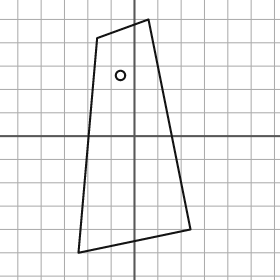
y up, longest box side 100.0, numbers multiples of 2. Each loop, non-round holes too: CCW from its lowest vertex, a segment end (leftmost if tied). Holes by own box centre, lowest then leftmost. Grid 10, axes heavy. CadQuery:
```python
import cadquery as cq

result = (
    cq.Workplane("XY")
    .moveTo(-24.0, -50.0)
    .lineTo(24.0, -40.0)
    .lineTo(6.0, 50.0)
    .lineTo(-16.0, 42.0)
    .close()
    .moveTo(-6.0, 26.0)
    .circle(2.0)
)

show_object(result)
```